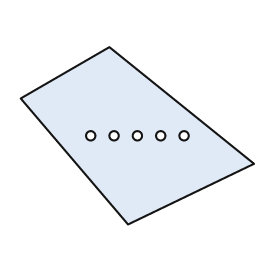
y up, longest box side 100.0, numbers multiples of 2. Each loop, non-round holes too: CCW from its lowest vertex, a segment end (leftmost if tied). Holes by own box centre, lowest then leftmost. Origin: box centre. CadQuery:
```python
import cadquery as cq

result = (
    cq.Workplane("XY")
    .moveTo(-4.0, -38.0)
    .lineTo(50.0, -12.0)
    .lineTo(-12.0, 38.0)
    .lineTo(-50.0, 16.0)
    .close()
    .moveTo(-20.0, 0.0)
    .circle(2.0)
    .moveTo(-10.0, 0.0)
    .circle(2.0)
    .moveTo(0.0, 0.0)
    .circle(2.0)
    .moveTo(10.0, 0.0)
    .circle(2.0)
    .moveTo(20.0, 0.0)
    .circle(2.0)
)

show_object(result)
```